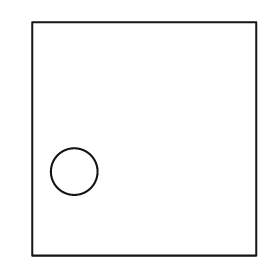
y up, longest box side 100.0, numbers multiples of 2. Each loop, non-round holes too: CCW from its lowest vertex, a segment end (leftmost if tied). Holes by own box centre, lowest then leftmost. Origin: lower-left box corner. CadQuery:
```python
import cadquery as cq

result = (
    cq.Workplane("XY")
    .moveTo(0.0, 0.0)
    .lineTo(96.0, 0.0)
    .lineTo(96.0, 100.0)
    .lineTo(0.0, 100.0)
    .close()
    .moveTo(18.0, 36.0)
    .circle(10.0)
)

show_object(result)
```